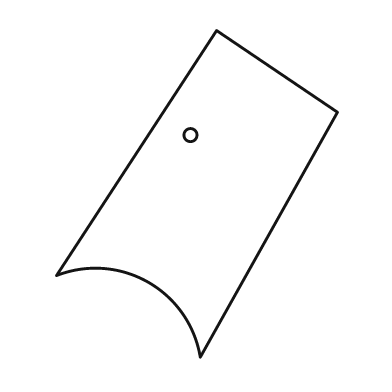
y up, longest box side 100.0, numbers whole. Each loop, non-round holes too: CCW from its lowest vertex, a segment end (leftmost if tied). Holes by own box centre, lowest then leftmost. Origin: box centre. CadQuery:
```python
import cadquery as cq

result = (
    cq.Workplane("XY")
    .moveTo(1.0, -50.0)
    .lineTo(43.0, 25.0)
    .lineTo(6.0, 50.0)
    .lineTo(-43.0, -25.0)
    .threePointArc((-15.0, -27.0), (1.0, -50.0))
    .close()
    .moveTo(-2.0, 18.0)
    .circle(2.0)
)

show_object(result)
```